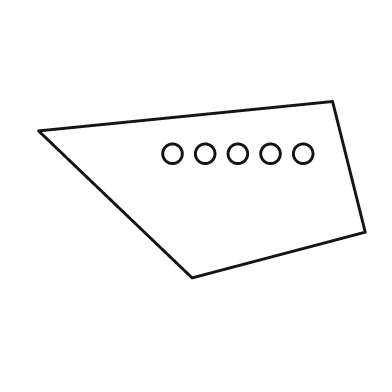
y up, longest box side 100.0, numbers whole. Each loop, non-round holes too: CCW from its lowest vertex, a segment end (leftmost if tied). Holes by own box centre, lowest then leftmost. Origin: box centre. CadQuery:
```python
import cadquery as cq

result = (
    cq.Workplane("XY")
    .moveTo(-3.0, -27.0)
    .lineTo(50.0, -13.0)
    .lineTo(40.0, 27.0)
    .lineTo(-50.0, 18.0)
    .close()
    .moveTo(-9.0, 11.0)
    .circle(3.0)
    .moveTo(1.0, 11.0)
    .circle(3.0)
    .moveTo(11.0, 11.0)
    .circle(3.0)
    .moveTo(21.0, 11.0)
    .circle(3.0)
    .moveTo(31.0, 11.0)
    .circle(3.0)
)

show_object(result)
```